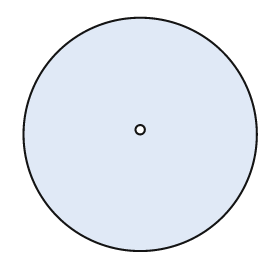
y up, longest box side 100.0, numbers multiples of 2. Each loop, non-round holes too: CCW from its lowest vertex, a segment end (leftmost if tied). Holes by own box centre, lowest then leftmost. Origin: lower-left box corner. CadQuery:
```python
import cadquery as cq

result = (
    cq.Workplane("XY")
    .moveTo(50.0, 50.0)
    .circle(50.0)
    .moveTo(50.0, 52.0)
    .circle(2.0)
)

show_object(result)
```